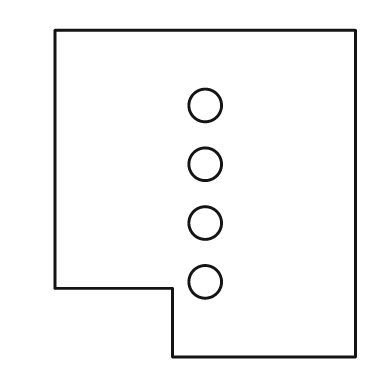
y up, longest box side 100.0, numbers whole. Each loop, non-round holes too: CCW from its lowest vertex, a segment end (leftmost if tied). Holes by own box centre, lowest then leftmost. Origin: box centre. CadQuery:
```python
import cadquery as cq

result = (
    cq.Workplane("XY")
    .moveTo(-10.0, -50.0)
    .lineTo(46.0, -50.0)
    .lineTo(46.0, 50.0)
    .lineTo(-46.0, 50.0)
    .lineTo(-46.0, -29.0)
    .lineTo(-10.0, -29.0)
    .close()
    .moveTo(0.0, -27.0)
    .circle(5.0)
    .moveTo(0.0, -9.0)
    .circle(5.0)
    .moveTo(0.0, 9.0)
    .circle(5.0)
    .moveTo(0.0, 27.0)
    .circle(5.0)
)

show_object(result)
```